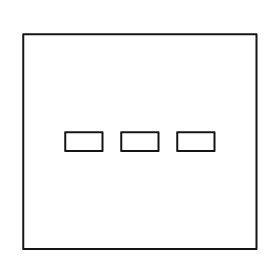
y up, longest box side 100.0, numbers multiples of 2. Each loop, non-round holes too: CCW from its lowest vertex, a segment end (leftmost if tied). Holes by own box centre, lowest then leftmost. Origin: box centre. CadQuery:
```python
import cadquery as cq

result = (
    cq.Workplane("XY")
    .moveTo(-50.0, -46.0)
    .lineTo(50.0, -46.0)
    .lineTo(50.0, 46.0)
    .lineTo(-50.0, 46.0)
    .close()
    .moveTo(-32.0, -4.0)
    .lineTo(-16.0, -4.0)
    .lineTo(-16.0, 4.0)
    .lineTo(-32.0, 4.0)
    .close()
    .moveTo(-8.0, -4.0)
    .lineTo(8.0, -4.0)
    .lineTo(8.0, 4.0)
    .lineTo(-8.0, 4.0)
    .close()
    .moveTo(16.0, -4.0)
    .lineTo(32.0, -4.0)
    .lineTo(32.0, 4.0)
    .lineTo(16.0, 4.0)
    .close()
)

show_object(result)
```